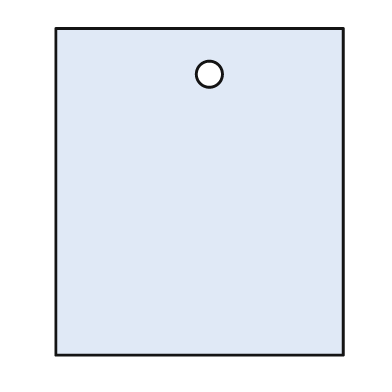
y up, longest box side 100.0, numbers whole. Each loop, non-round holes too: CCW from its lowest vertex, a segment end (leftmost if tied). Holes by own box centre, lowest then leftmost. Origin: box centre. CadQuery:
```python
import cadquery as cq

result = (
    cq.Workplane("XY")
    .moveTo(-44.0, -50.0)
    .lineTo(44.0, -50.0)
    .lineTo(44.0, 50.0)
    .lineTo(-44.0, 50.0)
    .close()
    .moveTo(3.0, 36.0)
    .circle(4.0)
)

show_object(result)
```